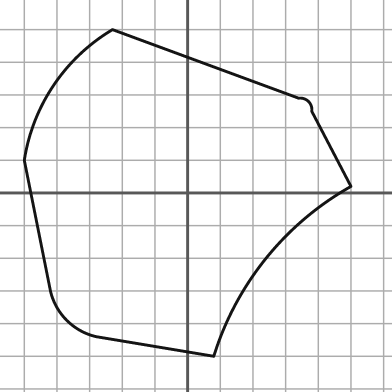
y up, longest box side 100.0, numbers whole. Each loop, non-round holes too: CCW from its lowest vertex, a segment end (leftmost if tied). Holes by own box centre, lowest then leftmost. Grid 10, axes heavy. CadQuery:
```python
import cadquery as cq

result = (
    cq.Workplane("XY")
    .moveTo(8.0, -50.0)
    .threePointArc((24.0, -20.0), (50.0, 2.0))
    .lineTo(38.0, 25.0)
    .threePointArc((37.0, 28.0), (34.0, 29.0))
    .lineTo(-23.0, 50.0)
    .threePointArc((-41.0, 33.0), (-50.0, 10.0))
    .lineTo(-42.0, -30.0)
    .threePointArc((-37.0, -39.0), (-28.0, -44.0))
    .close()
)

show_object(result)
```